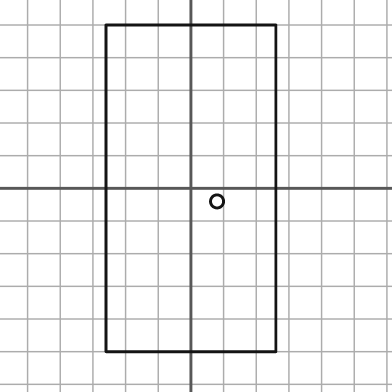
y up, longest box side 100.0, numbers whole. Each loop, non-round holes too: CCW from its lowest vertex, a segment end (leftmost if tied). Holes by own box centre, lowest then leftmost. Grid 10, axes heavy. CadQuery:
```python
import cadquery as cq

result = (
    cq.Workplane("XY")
    .moveTo(-26.0, -50.0)
    .lineTo(26.0, -50.0)
    .lineTo(26.0, 50.0)
    .lineTo(-26.0, 50.0)
    .close()
    .moveTo(8.0, -4.0)
    .circle(2.0)
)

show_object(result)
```